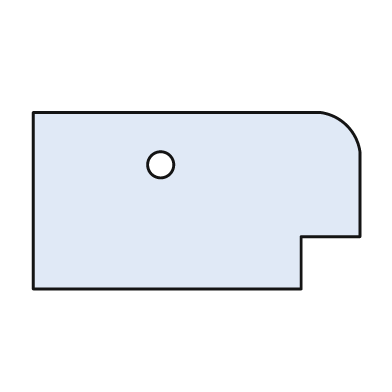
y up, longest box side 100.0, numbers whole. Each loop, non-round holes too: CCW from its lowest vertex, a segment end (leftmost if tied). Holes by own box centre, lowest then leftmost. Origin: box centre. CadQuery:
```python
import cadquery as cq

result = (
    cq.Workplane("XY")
    .moveTo(-50.0, -27.0)
    .lineTo(32.0, -27.0)
    .lineTo(32.0, -11.0)
    .lineTo(50.0, -11.0)
    .lineTo(50.0, 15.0)
    .threePointArc((46.0, 23.0), (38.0, 27.0))
    .lineTo(-50.0, 27.0)
    .close()
    .moveTo(-11.0, 11.0)
    .circle(4.0)
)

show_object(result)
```